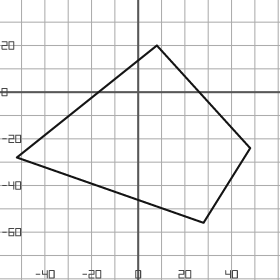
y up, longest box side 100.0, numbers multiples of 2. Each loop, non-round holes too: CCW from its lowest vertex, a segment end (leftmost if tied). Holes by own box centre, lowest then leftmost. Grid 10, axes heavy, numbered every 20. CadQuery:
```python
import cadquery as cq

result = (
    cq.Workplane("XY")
    .moveTo(28.0, -56.0)
    .lineTo(48.0, -24.0)
    .lineTo(8.0, 20.0)
    .lineTo(-52.0, -28.0)
    .close()
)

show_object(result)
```